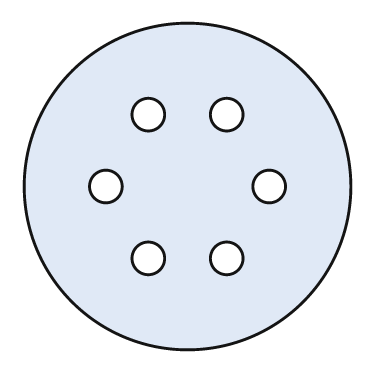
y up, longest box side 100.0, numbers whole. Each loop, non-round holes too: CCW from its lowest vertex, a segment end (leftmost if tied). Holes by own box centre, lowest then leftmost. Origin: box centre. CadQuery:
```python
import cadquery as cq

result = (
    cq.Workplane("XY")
    .moveTo(0.0, 0.0)
    .circle(50.0)
    .moveTo(-12.0, -22.0)
    .circle(5.0)
    .moveTo(12.0, -22.0)
    .circle(5.0)
    .moveTo(-25.0, 0.0)
    .circle(5.0)
    .moveTo(25.0, 0.0)
    .circle(5.0)
    .moveTo(-12.0, 22.0)
    .circle(5.0)
    .moveTo(12.0, 22.0)
    .circle(5.0)
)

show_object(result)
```